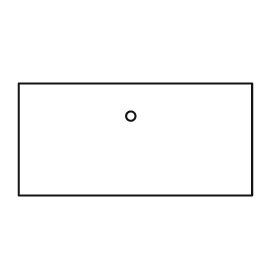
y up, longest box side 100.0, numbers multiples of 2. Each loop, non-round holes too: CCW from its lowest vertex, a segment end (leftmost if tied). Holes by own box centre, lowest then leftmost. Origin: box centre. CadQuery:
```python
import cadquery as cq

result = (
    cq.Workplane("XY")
    .moveTo(-50.0, -24.0)
    .lineTo(50.0, -24.0)
    .lineTo(50.0, 24.0)
    .lineTo(-50.0, 24.0)
    .close()
    .moveTo(-2.0, 10.0)
    .circle(2.0)
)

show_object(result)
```